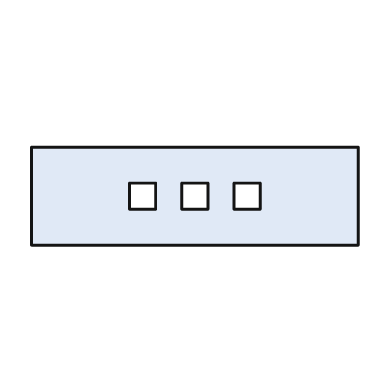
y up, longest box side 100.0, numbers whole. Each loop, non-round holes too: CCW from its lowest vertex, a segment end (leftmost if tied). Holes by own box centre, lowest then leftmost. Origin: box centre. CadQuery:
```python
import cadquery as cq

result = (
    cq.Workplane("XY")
    .moveTo(-50.0, -15.0)
    .lineTo(50.0, -15.0)
    .lineTo(50.0, 15.0)
    .lineTo(-50.0, 15.0)
    .close()
    .moveTo(-20.0, -4.0)
    .lineTo(-12.0, -4.0)
    .lineTo(-12.0, 4.0)
    .lineTo(-20.0, 4.0)
    .close()
    .moveTo(-4.0, -4.0)
    .lineTo(4.0, -4.0)
    .lineTo(4.0, 4.0)
    .lineTo(-4.0, 4.0)
    .close()
    .moveTo(12.0, -4.0)
    .lineTo(20.0, -4.0)
    .lineTo(20.0, 4.0)
    .lineTo(12.0, 4.0)
    .close()
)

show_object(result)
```